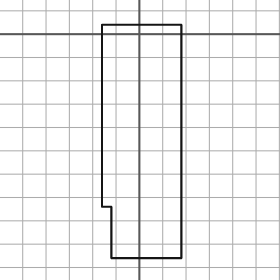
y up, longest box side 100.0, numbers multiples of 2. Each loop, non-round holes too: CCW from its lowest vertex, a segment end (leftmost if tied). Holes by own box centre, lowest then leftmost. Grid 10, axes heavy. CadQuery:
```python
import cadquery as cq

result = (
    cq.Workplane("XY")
    .moveTo(-12.0, -96.0)
    .lineTo(18.0, -96.0)
    .lineTo(18.0, 4.0)
    .lineTo(-16.0, 4.0)
    .lineTo(-16.0, -74.0)
    .lineTo(-12.0, -74.0)
    .close()
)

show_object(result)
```